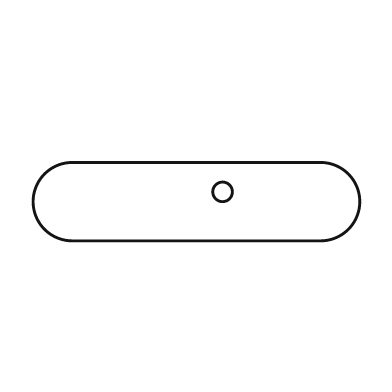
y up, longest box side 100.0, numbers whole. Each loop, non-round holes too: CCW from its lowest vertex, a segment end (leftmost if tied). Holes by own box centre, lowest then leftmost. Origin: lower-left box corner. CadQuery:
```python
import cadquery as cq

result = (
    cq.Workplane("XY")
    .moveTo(12.0, 0.0)
    .lineTo(88.0, 0.0)
    .threePointArc((100.0, 12.0), (88.0, 24.0))
    .lineTo(12.0, 24.0)
    .threePointArc((0.0, 12.0), (12.0, 0.0))
    .close()
    .moveTo(58.0, 15.0)
    .circle(3.0)
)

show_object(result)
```